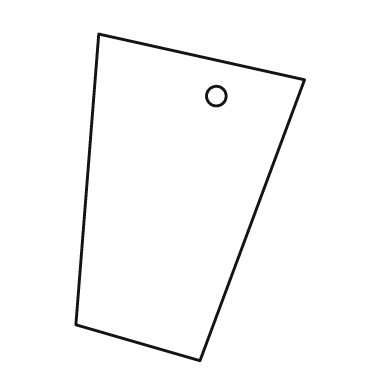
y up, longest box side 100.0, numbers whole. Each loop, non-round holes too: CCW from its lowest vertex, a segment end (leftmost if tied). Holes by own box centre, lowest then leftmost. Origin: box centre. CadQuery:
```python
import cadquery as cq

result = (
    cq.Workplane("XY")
    .moveTo(3.0, -50.0)
    .lineTo(35.0, 36.0)
    .lineTo(-28.0, 50.0)
    .lineTo(-35.0, -39.0)
    .close()
    .moveTo(8.0, 31.0)
    .circle(3.0)
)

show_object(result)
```